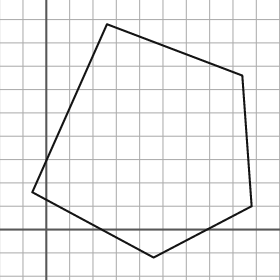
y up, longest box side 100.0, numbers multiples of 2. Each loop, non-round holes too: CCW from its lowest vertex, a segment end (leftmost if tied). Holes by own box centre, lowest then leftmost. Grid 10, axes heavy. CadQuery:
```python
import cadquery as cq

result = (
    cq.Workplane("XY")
    .moveTo(46.0, -12.0)
    .lineTo(88.0, 10.0)
    .lineTo(84.0, 66.0)
    .lineTo(26.0, 88.0)
    .lineTo(-6.0, 16.0)
    .close()
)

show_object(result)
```